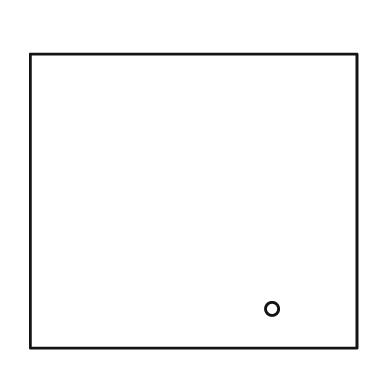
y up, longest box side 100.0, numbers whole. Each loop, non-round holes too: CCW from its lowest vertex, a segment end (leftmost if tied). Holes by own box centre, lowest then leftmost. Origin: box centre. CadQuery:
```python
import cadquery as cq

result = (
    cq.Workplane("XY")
    .moveTo(-50.0, -45.0)
    .lineTo(50.0, -45.0)
    .lineTo(50.0, 45.0)
    .lineTo(-50.0, 45.0)
    .close()
    .moveTo(24.0, -33.0)
    .circle(2.0)
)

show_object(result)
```